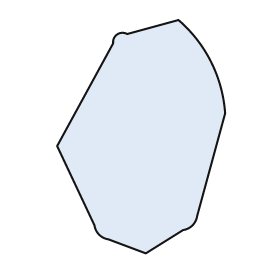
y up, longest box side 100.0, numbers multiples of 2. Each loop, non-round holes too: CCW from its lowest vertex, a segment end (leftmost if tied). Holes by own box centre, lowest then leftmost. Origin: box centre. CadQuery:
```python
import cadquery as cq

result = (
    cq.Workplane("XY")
    .moveTo(2.0, -50.0)
    .lineTo(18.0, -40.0)
    .threePointArc((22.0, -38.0), (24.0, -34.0))
    .lineTo(36.0, 10.0)
    .threePointArc((30.0, 32.0), (16.0, 50.0))
    .lineTo(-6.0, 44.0)
    .threePointArc((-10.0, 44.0), (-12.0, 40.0))
    .lineTo(-36.0, -4.0)
    .lineTo(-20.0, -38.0)
    .threePointArc((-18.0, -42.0), (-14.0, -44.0))
    .close()
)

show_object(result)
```